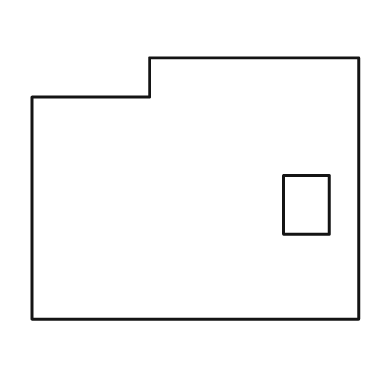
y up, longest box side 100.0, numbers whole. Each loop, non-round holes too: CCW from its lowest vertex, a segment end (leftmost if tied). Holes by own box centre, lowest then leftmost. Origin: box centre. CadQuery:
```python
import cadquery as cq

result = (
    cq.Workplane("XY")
    .moveTo(-50.0, -40.0)
    .lineTo(50.0, -40.0)
    .lineTo(50.0, 40.0)
    .lineTo(-14.0, 40.0)
    .lineTo(-14.0, 28.0)
    .lineTo(-50.0, 28.0)
    .close()
    .moveTo(27.0, -14.0)
    .lineTo(41.0, -14.0)
    .lineTo(41.0, 4.0)
    .lineTo(27.0, 4.0)
    .close()
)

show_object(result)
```